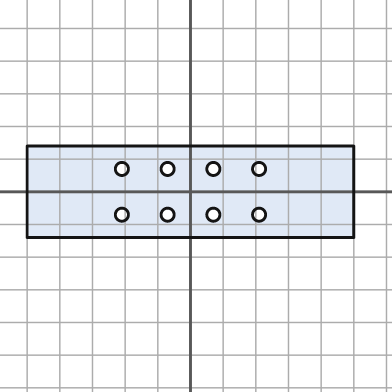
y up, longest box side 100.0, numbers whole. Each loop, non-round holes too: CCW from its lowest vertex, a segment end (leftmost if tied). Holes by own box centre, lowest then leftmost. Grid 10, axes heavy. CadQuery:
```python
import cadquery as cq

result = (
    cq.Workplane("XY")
    .moveTo(-50.0, -14.0)
    .lineTo(50.0, -14.0)
    .lineTo(50.0, 14.0)
    .lineTo(-50.0, 14.0)
    .close()
    .moveTo(-21.0, -7.0)
    .circle(2.0)
    .moveTo(-7.0, -7.0)
    .circle(2.0)
    .moveTo(7.0, -7.0)
    .circle(2.0)
    .moveTo(21.0, -7.0)
    .circle(2.0)
    .moveTo(-21.0, 7.0)
    .circle(2.0)
    .moveTo(-7.0, 7.0)
    .circle(2.0)
    .moveTo(7.0, 7.0)
    .circle(2.0)
    .moveTo(21.0, 7.0)
    .circle(2.0)
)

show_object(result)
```